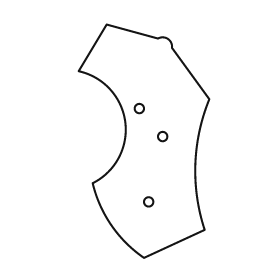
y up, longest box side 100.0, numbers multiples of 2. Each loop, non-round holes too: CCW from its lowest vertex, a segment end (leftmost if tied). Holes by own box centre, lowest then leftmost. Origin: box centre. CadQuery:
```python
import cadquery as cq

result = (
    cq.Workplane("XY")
    .moveTo(0.0, -50.0)
    .lineTo(26.0, -38.0)
    .threePointArc((22.0, -10.0), (28.0, 18.0))
    .lineTo(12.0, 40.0)
    .threePointArc((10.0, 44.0), (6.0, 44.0))
    .lineTo(-16.0, 50.0)
    .lineTo(-28.0, 30.0)
    .threePointArc((-8.0, 8.0), (-22.0, -18.0))
    .threePointArc((-14.0, -36.0), (0.0, -50.0))
    .close()
    .moveTo(2.0, -26.0)
    .circle(2.0)
    .moveTo(8.0, 2.0)
    .circle(2.0)
    .moveTo(-2.0, 14.0)
    .circle(2.0)
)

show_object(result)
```